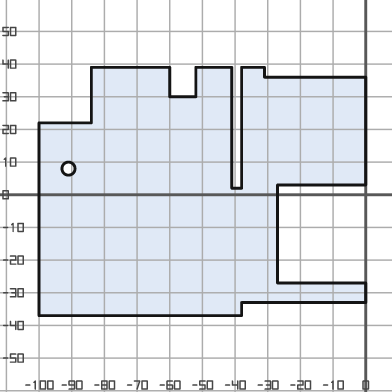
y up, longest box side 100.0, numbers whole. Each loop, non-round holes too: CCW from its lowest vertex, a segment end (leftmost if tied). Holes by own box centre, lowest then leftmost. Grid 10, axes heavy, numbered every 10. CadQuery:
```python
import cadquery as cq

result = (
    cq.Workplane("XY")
    .moveTo(-100.0, -37.0)
    .lineTo(-38.0, -37.0)
    .lineTo(-38.0, -33.0)
    .lineTo(0.0, -33.0)
    .lineTo(0.0, -27.0)
    .lineTo(-27.0, -27.0)
    .lineTo(-27.0, 3.0)
    .lineTo(0.0, 3.0)
    .lineTo(0.0, 36.0)
    .lineTo(-31.0, 36.0)
    .lineTo(-31.0, 39.0)
    .lineTo(-38.0, 39.0)
    .lineTo(-38.0, 2.0)
    .lineTo(-41.0, 2.0)
    .lineTo(-41.0, 39.0)
    .lineTo(-52.0, 39.0)
    .lineTo(-52.0, 30.0)
    .lineTo(-60.0, 30.0)
    .lineTo(-60.0, 39.0)
    .lineTo(-84.0, 39.0)
    .lineTo(-84.0, 22.0)
    .lineTo(-100.0, 22.0)
    .close()
    .moveTo(-91.0, 8.0)
    .circle(2.0)
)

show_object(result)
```